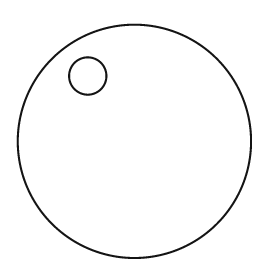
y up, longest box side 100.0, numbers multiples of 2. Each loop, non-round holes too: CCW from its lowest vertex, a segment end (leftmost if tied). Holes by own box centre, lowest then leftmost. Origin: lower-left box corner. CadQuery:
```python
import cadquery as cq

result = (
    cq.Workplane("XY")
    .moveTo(50.0, 50.0)
    .circle(50.0)
    .moveTo(30.0, 78.0)
    .circle(8.0)
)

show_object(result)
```